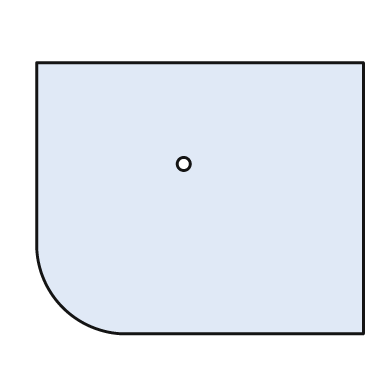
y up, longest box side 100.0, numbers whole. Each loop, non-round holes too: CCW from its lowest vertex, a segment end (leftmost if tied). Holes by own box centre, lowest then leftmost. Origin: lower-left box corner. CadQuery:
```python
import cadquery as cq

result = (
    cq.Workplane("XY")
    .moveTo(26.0, 0.0)
    .lineTo(100.0, 0.0)
    .lineTo(100.0, 83.0)
    .lineTo(0.0, 83.0)
    .lineTo(0.0, 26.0)
    .threePointArc((8.0, 8.0), (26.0, 0.0))
    .close()
    .moveTo(45.0, 52.0)
    .circle(2.0)
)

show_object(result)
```